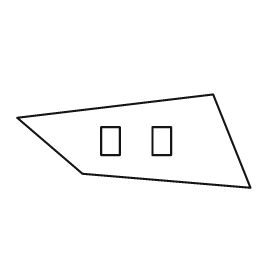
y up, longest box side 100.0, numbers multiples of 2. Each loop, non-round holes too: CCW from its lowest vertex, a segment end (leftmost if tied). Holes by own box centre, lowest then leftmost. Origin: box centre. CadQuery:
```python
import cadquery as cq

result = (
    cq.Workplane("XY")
    .moveTo(50.0, -20.0)
    .lineTo(34.0, 20.0)
    .lineTo(-50.0, 10.0)
    .lineTo(-22.0, -14.0)
    .close()
    .moveTo(-14.0, -6.0)
    .lineTo(-6.0, -6.0)
    .lineTo(-6.0, 6.0)
    .lineTo(-14.0, 6.0)
    .close()
    .moveTo(8.0, -6.0)
    .lineTo(16.0, -6.0)
    .lineTo(16.0, 6.0)
    .lineTo(8.0, 6.0)
    .close()
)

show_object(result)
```